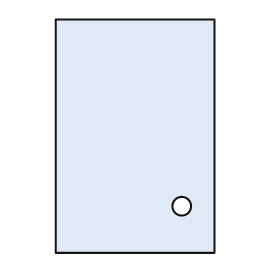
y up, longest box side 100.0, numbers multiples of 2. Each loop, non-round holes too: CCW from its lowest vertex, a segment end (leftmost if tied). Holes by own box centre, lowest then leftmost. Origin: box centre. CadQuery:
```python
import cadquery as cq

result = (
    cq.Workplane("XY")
    .moveTo(-34.0, -50.0)
    .lineTo(34.0, -50.0)
    .lineTo(34.0, 50.0)
    .lineTo(-34.0, 50.0)
    .close()
    .moveTo(20.0, -30.0)
    .circle(4.0)
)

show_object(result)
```